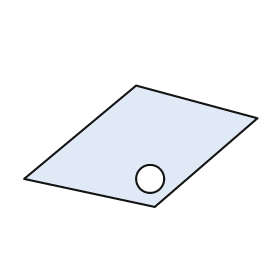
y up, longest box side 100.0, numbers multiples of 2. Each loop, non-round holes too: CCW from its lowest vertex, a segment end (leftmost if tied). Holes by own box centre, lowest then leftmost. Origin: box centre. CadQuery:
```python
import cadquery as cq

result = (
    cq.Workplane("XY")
    .moveTo(6.0, -26.0)
    .lineTo(50.0, 12.0)
    .lineTo(-2.0, 26.0)
    .lineTo(-50.0, -14.0)
    .close()
    .moveTo(4.0, -14.0)
    .circle(6.0)
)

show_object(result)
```